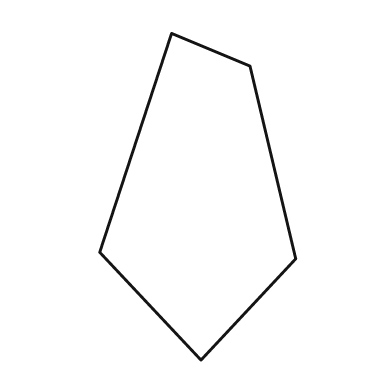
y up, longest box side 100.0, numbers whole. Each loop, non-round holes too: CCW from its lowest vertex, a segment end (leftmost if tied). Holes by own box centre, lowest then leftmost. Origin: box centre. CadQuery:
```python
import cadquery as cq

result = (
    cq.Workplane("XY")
    .moveTo(1.0, -50.0)
    .lineTo(30.0, -19.0)
    .lineTo(16.0, 40.0)
    .lineTo(-8.0, 50.0)
    .lineTo(-30.0, -17.0)
    .close()
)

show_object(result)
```